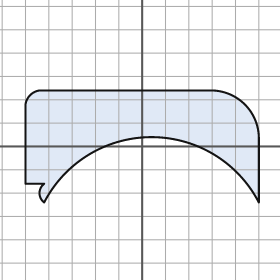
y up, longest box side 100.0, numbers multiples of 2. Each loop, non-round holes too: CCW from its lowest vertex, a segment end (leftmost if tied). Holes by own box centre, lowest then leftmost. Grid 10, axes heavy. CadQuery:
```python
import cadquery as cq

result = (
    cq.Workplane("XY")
    .moveTo(-42.0, -24.0)
    .threePointArc((4.0, 4.0), (50.0, -24.0))
    .lineTo(50.0, 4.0)
    .threePointArc((44.0, 18.0), (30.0, 24.0))
    .lineTo(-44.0, 24.0)
    .threePointArc((-48.0, 22.0), (-50.0, 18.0))
    .lineTo(-50.0, -16.0)
    .lineTo(-42.0, -16.0)
    .threePointArc((-44.0, -20.0), (-42.0, -24.0))
    .close()
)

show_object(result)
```